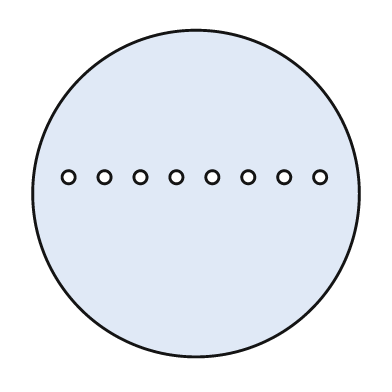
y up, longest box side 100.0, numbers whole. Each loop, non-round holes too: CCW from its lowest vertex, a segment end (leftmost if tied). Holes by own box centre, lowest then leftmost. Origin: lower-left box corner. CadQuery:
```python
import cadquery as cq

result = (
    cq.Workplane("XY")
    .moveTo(50.0, 50.0)
    .circle(50.0)
    .moveTo(11.0, 55.0)
    .circle(2.0)
    .moveTo(22.0, 55.0)
    .circle(2.0)
    .moveTo(33.0, 55.0)
    .circle(2.0)
    .moveTo(44.0, 55.0)
    .circle(2.0)
    .moveTo(55.0, 55.0)
    .circle(2.0)
    .moveTo(66.0, 55.0)
    .circle(2.0)
    .moveTo(77.0, 55.0)
    .circle(2.0)
    .moveTo(88.0, 55.0)
    .circle(2.0)
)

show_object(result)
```